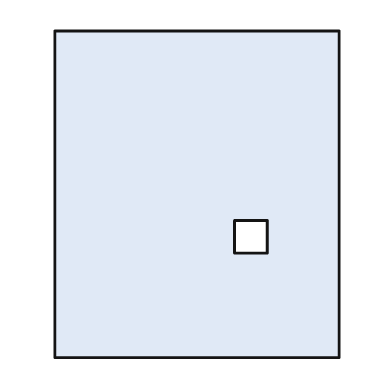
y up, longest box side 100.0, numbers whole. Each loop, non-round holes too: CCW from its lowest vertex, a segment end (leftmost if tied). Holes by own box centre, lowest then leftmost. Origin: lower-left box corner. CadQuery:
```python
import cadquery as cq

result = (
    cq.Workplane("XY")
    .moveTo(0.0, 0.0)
    .lineTo(87.0, 0.0)
    .lineTo(87.0, 100.0)
    .lineTo(0.0, 100.0)
    .close()
    .moveTo(55.0, 32.0)
    .lineTo(65.0, 32.0)
    .lineTo(65.0, 42.0)
    .lineTo(55.0, 42.0)
    .close()
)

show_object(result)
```